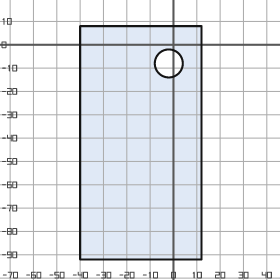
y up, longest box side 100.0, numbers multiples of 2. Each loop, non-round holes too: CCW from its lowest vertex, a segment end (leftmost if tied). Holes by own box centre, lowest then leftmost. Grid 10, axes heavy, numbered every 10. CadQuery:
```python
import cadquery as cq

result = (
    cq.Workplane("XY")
    .moveTo(-40.0, -92.0)
    .lineTo(12.0, -92.0)
    .lineTo(12.0, 8.0)
    .lineTo(-40.0, 8.0)
    .close()
    .moveTo(-2.0, -8.0)
    .circle(6.0)
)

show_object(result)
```